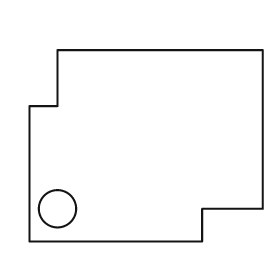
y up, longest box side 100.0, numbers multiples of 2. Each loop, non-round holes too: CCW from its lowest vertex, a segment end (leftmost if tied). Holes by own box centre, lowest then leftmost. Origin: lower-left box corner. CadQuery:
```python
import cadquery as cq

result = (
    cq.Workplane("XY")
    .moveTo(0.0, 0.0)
    .lineTo(74.0, 0.0)
    .lineTo(74.0, 14.0)
    .lineTo(100.0, 14.0)
    .lineTo(100.0, 82.0)
    .lineTo(12.0, 82.0)
    .lineTo(12.0, 58.0)
    .lineTo(0.0, 58.0)
    .close()
    .moveTo(12.0, 14.0)
    .circle(8.0)
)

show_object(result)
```